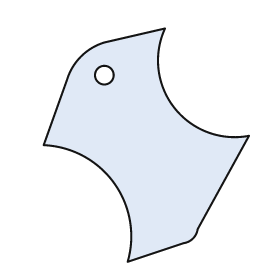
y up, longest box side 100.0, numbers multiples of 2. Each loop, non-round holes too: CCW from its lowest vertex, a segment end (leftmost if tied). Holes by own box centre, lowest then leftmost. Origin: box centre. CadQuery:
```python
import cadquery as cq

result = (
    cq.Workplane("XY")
    .moveTo(-8.0, -50.0)
    .lineTo(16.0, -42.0)
    .threePointArc((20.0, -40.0), (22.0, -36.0))
    .lineTo(44.0, 4.0)
    .threePointArc((12.0, 16.0), (8.0, 50.0))
    .lineTo(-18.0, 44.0)
    .threePointArc((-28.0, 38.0), (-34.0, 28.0))
    .lineTo(-44.0, 0.0)
    .threePointArc((-14.0, -16.0), (-8.0, -50.0))
    .close()
    .moveTo(-18.0, 30.0)
    .circle(4.0)
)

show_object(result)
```